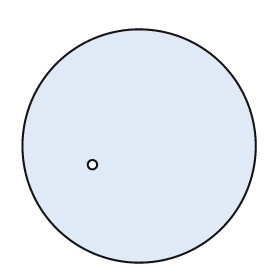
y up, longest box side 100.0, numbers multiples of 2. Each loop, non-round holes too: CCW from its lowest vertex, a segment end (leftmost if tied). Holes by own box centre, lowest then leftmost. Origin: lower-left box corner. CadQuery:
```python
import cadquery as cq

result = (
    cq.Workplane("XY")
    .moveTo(50.0, 50.0)
    .circle(50.0)
    .moveTo(30.0, 42.0)
    .circle(2.0)
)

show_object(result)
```